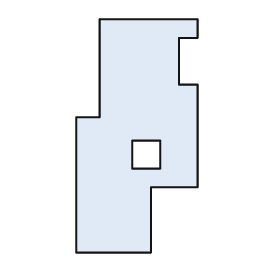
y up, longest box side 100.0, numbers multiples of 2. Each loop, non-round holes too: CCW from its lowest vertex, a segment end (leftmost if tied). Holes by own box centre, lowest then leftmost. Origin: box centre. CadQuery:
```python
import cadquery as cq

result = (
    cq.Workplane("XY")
    .moveTo(-26.0, -50.0)
    .lineTo(6.0, -50.0)
    .lineTo(6.0, -22.0)
    .lineTo(26.0, -22.0)
    .lineTo(26.0, 22.0)
    .lineTo(18.0, 22.0)
    .lineTo(18.0, 42.0)
    .lineTo(26.0, 42.0)
    .lineTo(26.0, 50.0)
    .lineTo(-16.0, 50.0)
    .lineTo(-16.0, 8.0)
    .lineTo(-26.0, 8.0)
    .close()
    .moveTo(-2.0, -14.0)
    .lineTo(10.0, -14.0)
    .lineTo(10.0, -2.0)
    .lineTo(-2.0, -2.0)
    .close()
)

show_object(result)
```